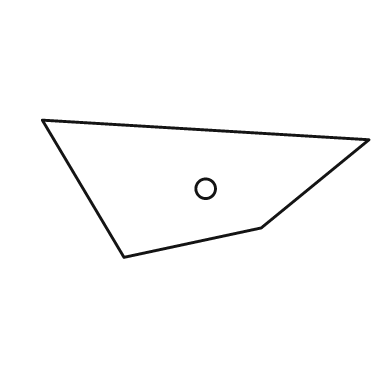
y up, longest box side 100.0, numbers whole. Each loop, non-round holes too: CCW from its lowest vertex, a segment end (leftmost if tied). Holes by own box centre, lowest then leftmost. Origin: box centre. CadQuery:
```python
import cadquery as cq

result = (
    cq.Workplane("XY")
    .moveTo(-25.0, -21.0)
    .lineTo(17.0, -12.0)
    .lineTo(50.0, 15.0)
    .lineTo(-50.0, 21.0)
    .close()
    .moveTo(0.0, 0.0)
    .circle(3.0)
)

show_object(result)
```